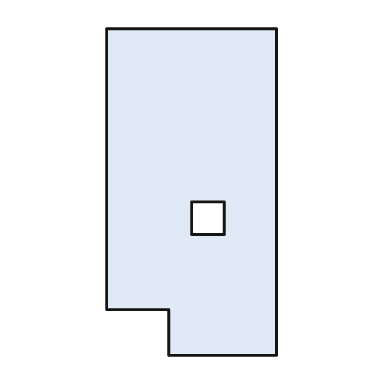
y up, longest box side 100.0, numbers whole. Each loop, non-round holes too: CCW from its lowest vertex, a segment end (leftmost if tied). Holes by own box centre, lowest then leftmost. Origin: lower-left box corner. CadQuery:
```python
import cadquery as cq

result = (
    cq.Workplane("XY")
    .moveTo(19.0, 0.0)
    .lineTo(52.0, 0.0)
    .lineTo(52.0, 100.0)
    .lineTo(0.0, 100.0)
    .lineTo(0.0, 14.0)
    .lineTo(19.0, 14.0)
    .close()
    .moveTo(26.0, 37.0)
    .lineTo(36.0, 37.0)
    .lineTo(36.0, 47.0)
    .lineTo(26.0, 47.0)
    .close()
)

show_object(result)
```